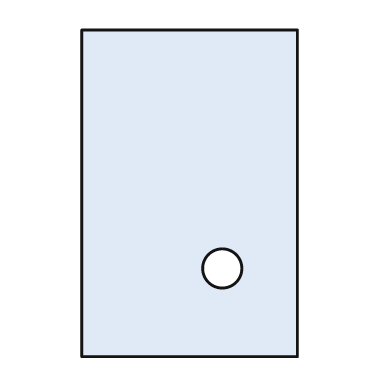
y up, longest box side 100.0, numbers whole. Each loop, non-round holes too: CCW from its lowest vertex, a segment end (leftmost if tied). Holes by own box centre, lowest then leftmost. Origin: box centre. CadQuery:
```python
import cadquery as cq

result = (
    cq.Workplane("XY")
    .moveTo(-33.0, -50.0)
    .lineTo(33.0, -50.0)
    .lineTo(33.0, 50.0)
    .lineTo(-33.0, 50.0)
    .close()
    .moveTo(10.0, -23.0)
    .circle(6.0)
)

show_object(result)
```